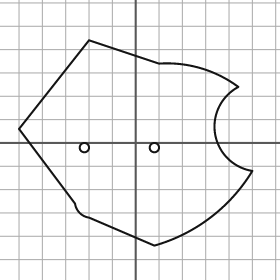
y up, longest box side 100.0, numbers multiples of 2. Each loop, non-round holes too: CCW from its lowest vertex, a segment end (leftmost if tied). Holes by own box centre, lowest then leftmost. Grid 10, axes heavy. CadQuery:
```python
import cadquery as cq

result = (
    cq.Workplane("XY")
    .moveTo(8.0, -44.0)
    .threePointArc((32.0, -32.0), (50.0, -12.0))
    .threePointArc((34.0, 4.0), (44.0, 24.0))
    .threePointArc((28.0, 32.0), (10.0, 34.0))
    .lineTo(-20.0, 44.0)
    .lineTo(-50.0, 6.0)
    .lineTo(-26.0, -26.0)
    .threePointArc((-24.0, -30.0), (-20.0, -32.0))
    .close()
    .moveTo(-22.0, -2.0)
    .circle(2.0)
    .moveTo(8.0, -2.0)
    .circle(2.0)
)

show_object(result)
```